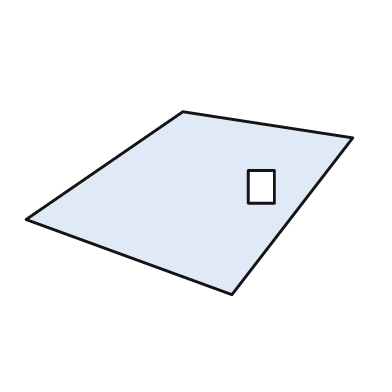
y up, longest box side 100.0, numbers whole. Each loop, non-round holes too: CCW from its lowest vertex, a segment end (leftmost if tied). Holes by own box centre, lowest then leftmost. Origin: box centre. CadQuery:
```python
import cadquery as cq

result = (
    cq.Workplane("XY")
    .moveTo(13.0, -28.0)
    .lineTo(50.0, 20.0)
    .lineTo(-2.0, 28.0)
    .lineTo(-50.0, -5.0)
    .close()
    .moveTo(18.0, 0.0)
    .lineTo(26.0, 0.0)
    .lineTo(26.0, 10.0)
    .lineTo(18.0, 10.0)
    .close()
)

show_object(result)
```